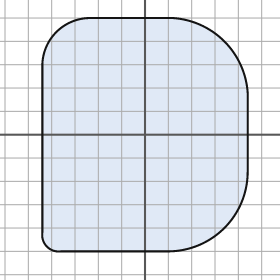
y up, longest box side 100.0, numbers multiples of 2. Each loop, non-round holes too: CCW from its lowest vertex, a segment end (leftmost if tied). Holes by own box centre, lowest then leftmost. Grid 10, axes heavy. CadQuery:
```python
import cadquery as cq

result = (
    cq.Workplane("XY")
    .moveTo(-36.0, -50.0)
    .lineTo(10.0, -50.0)
    .threePointArc((34.0, -40.0), (44.0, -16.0))
    .lineTo(44.0, 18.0)
    .threePointArc((34.0, 40.0), (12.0, 50.0))
    .lineTo(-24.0, 50.0)
    .threePointArc((-38.0, 44.0), (-44.0, 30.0))
    .lineTo(-44.0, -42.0)
    .threePointArc((-42.0, -48.0), (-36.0, -50.0))
    .close()
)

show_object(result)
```